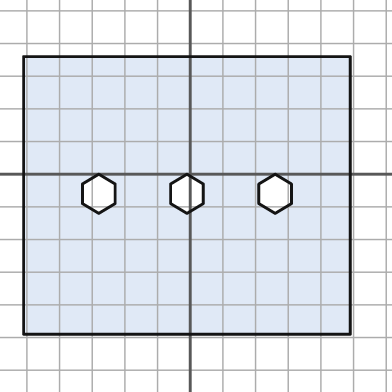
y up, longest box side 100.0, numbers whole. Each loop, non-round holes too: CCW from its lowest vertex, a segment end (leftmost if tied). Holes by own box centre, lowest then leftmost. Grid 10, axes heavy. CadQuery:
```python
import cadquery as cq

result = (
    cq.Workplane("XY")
    .moveTo(-51.0, -49.0)
    .lineTo(49.0, -49.0)
    .lineTo(49.0, 36.0)
    .lineTo(-51.0, 36.0)
    .close()
    .moveTo(-28.0, -12.0)
    .lineTo(-23.0, -9.0)
    .lineTo(-23.0, -3.0)
    .lineTo(-28.0, 0.0)
    .lineTo(-33.0, -3.0)
    .lineTo(-33.0, -9.0)
    .close()
    .moveTo(-1.0, -12.0)
    .lineTo(4.0, -9.0)
    .lineTo(4.0, -3.0)
    .lineTo(-1.0, 0.0)
    .lineTo(-6.0, -3.0)
    .lineTo(-6.0, -9.0)
    .close()
    .moveTo(26.0, -12.0)
    .lineTo(31.0, -9.0)
    .lineTo(31.0, -3.0)
    .lineTo(26.0, 0.0)
    .lineTo(21.0, -3.0)
    .lineTo(21.0, -9.0)
    .close()
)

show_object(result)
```